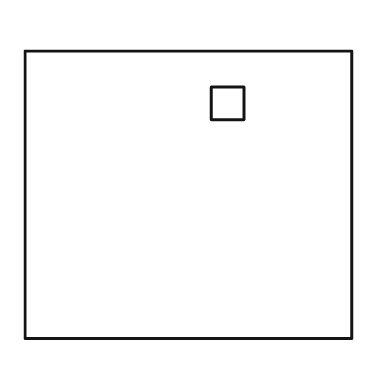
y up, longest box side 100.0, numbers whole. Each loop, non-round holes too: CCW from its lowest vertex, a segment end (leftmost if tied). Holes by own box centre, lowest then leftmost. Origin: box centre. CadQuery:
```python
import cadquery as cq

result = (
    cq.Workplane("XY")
    .moveTo(-50.0, -44.0)
    .lineTo(50.0, -44.0)
    .lineTo(50.0, 44.0)
    .lineTo(-50.0, 44.0)
    .close()
    .moveTo(7.0, 23.0)
    .lineTo(17.0, 23.0)
    .lineTo(17.0, 33.0)
    .lineTo(7.0, 33.0)
    .close()
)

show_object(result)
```